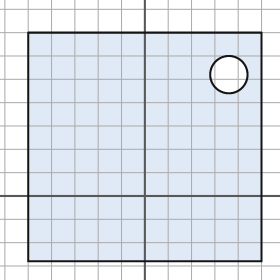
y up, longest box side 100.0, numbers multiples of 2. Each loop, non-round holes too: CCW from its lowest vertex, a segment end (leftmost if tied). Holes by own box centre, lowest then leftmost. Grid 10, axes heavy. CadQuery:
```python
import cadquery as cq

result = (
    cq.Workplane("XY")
    .moveTo(-50.0, -28.0)
    .lineTo(50.0, -28.0)
    .lineTo(50.0, 70.0)
    .lineTo(-50.0, 70.0)
    .close()
    .moveTo(36.0, 52.0)
    .circle(8.0)
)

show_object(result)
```